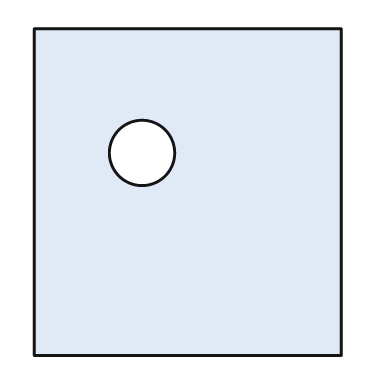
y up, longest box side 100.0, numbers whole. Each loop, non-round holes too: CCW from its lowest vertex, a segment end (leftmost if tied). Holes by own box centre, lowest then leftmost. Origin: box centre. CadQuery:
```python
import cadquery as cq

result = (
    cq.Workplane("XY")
    .moveTo(-47.0, -50.0)
    .lineTo(47.0, -50.0)
    .lineTo(47.0, 50.0)
    .lineTo(-47.0, 50.0)
    .close()
    .moveTo(-14.0, 12.0)
    .circle(10.0)
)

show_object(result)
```